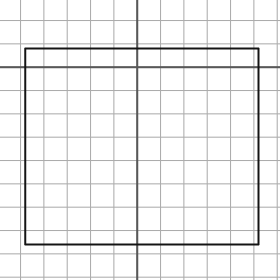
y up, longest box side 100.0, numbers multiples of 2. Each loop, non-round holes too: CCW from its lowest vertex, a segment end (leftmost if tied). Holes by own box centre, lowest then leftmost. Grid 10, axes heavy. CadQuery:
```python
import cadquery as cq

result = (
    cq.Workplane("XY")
    .moveTo(-48.0, -76.0)
    .lineTo(52.0, -76.0)
    .lineTo(52.0, 8.0)
    .lineTo(-48.0, 8.0)
    .close()
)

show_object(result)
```